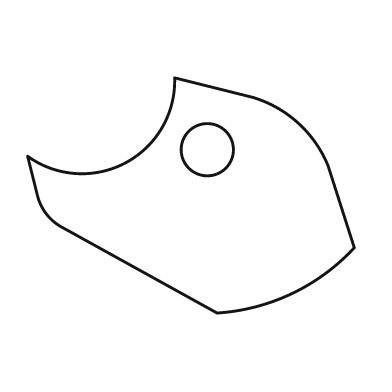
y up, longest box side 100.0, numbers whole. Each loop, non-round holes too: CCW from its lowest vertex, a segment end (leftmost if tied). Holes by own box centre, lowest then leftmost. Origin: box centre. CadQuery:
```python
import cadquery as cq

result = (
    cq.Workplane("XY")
    .moveTo(8.0, -36.0)
    .threePointArc((31.0, -30.0), (50.0, -16.0))
    .lineTo(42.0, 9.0)
    .threePointArc((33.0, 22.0), (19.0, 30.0))
    .lineTo(-5.0, 36.0)
    .threePointArc((-20.0, 10.0), (-50.0, 12.0))
    .lineTo(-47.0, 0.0)
    .threePointArc((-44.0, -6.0), (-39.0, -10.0))
    .close()
    .moveTo(5.0, 14.0)
    .circle(8.0)
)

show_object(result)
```